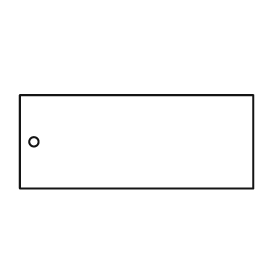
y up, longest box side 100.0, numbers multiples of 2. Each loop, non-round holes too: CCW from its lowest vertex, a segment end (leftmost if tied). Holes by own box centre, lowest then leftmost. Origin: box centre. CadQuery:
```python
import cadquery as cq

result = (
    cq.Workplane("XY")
    .moveTo(-50.0, -20.0)
    .lineTo(50.0, -20.0)
    .lineTo(50.0, 20.0)
    .lineTo(-50.0, 20.0)
    .close()
    .moveTo(-44.0, 0.0)
    .circle(2.0)
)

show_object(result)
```